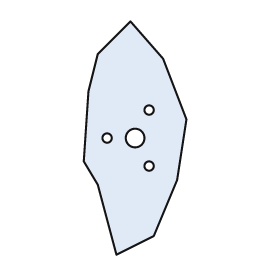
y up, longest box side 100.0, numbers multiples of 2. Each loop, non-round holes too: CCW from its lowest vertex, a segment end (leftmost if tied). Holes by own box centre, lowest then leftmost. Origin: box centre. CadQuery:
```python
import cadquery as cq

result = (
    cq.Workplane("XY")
    .moveTo(-8.0, -50.0)
    .lineTo(8.0, -42.0)
    .lineTo(18.0, -18.0)
    .lineTo(22.0, 8.0)
    .lineTo(12.0, 34.0)
    .lineTo(-2.0, 50.0)
    .lineTo(-16.0, 36.0)
    .lineTo(-20.0, 20.0)
    .lineTo(-22.0, -10.0)
    .lineTo(-16.0, -20.0)
    .close()
    .moveTo(6.0, -12.0)
    .circle(2.0)
    .moveTo(-12.0, 0.0)
    .circle(2.0)
    .moveTo(0.0, 0.0)
    .circle(4.0)
    .moveTo(6.0, 12.0)
    .circle(2.0)
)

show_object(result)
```